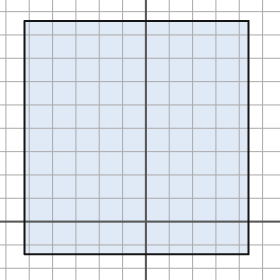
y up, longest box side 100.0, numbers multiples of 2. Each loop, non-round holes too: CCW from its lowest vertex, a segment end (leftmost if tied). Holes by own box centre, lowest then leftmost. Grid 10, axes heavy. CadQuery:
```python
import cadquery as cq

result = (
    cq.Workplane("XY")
    .moveTo(-52.0, -14.0)
    .lineTo(44.0, -14.0)
    .lineTo(44.0, 86.0)
    .lineTo(-52.0, 86.0)
    .close()
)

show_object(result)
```